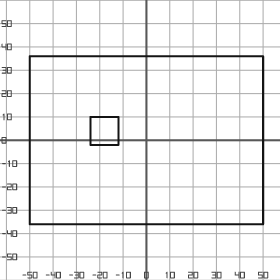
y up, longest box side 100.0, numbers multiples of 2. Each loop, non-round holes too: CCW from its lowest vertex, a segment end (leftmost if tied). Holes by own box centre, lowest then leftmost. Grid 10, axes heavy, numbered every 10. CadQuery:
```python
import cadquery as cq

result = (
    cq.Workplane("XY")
    .moveTo(-50.0, -36.0)
    .lineTo(50.0, -36.0)
    .lineTo(50.0, 36.0)
    .lineTo(-50.0, 36.0)
    .close()
    .moveTo(-24.0, -2.0)
    .lineTo(-12.0, -2.0)
    .lineTo(-12.0, 10.0)
    .lineTo(-24.0, 10.0)
    .close()
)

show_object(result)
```